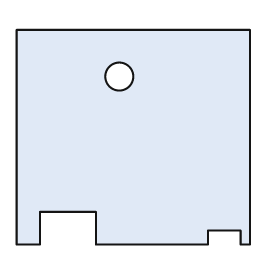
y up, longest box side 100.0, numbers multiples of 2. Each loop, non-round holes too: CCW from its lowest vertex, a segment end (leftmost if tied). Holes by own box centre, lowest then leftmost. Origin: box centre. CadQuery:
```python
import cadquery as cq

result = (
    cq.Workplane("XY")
    .moveTo(-50.0, -46.0)
    .lineTo(-40.0, -46.0)
    .lineTo(-40.0, -32.0)
    .lineTo(-16.0, -32.0)
    .lineTo(-16.0, -46.0)
    .lineTo(32.0, -46.0)
    .lineTo(32.0, -40.0)
    .lineTo(46.0, -40.0)
    .lineTo(46.0, -46.0)
    .lineTo(50.0, -46.0)
    .lineTo(50.0, 46.0)
    .lineTo(-50.0, 46.0)
    .close()
    .moveTo(-6.0, 26.0)
    .circle(6.0)
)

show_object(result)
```